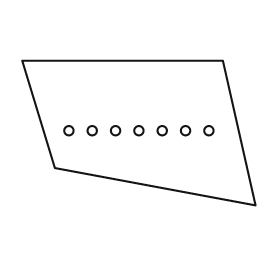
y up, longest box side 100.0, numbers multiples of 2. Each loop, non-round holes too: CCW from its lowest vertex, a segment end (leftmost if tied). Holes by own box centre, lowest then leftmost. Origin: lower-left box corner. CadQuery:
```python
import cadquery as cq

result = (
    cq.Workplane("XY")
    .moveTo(100.0, 0.0)
    .lineTo(86.0, 62.0)
    .lineTo(0.0, 62.0)
    .lineTo(14.0, 16.0)
    .close()
    .moveTo(20.0, 32.0)
    .circle(2.0)
    .moveTo(30.0, 32.0)
    .circle(2.0)
    .moveTo(40.0, 32.0)
    .circle(2.0)
    .moveTo(50.0, 32.0)
    .circle(2.0)
    .moveTo(60.0, 32.0)
    .circle(2.0)
    .moveTo(70.0, 32.0)
    .circle(2.0)
    .moveTo(80.0, 32.0)
    .circle(2.0)
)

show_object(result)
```